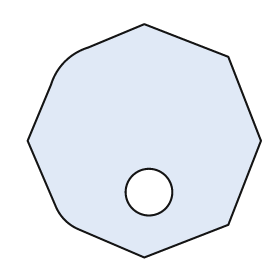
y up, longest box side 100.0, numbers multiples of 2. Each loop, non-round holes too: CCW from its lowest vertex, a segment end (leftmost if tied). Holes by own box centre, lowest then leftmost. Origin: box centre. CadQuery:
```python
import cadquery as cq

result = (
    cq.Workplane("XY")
    .moveTo(0.0, -50.0)
    .lineTo(36.0, -36.0)
    .lineTo(50.0, 0.0)
    .lineTo(36.0, 36.0)
    .lineTo(0.0, 50.0)
    .lineTo(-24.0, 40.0)
    .threePointArc((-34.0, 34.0), (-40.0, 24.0))
    .lineTo(-50.0, 0.0)
    .lineTo(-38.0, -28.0)
    .threePointArc((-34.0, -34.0), (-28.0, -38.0))
    .close()
    .moveTo(2.0, -22.0)
    .circle(10.0)
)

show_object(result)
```